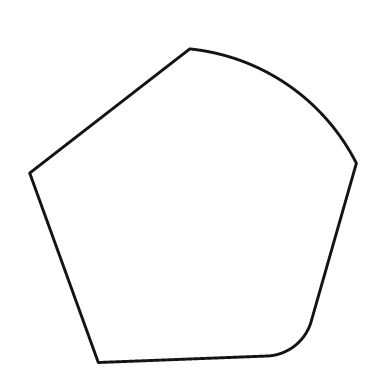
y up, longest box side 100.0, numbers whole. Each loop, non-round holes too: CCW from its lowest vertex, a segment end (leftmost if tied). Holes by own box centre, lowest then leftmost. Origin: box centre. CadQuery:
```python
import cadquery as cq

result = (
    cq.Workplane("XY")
    .moveTo(-29.0, -48.0)
    .lineTo(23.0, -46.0)
    .threePointArc((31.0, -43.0), (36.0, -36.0))
    .lineTo(50.0, 13.0)
    .threePointArc((29.0, 37.0), (-1.0, 48.0))
    .lineTo(-50.0, 10.0)
    .close()
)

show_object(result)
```